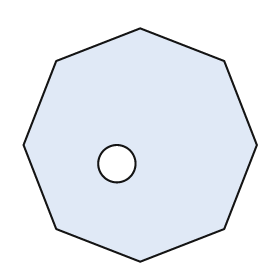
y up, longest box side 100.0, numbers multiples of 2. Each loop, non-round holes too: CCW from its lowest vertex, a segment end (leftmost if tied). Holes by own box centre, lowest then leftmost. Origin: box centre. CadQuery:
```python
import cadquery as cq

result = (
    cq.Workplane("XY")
    .moveTo(0.0, -50.0)
    .lineTo(36.0, -36.0)
    .lineTo(50.0, 0.0)
    .lineTo(36.0, 36.0)
    .lineTo(0.0, 50.0)
    .lineTo(-36.0, 36.0)
    .lineTo(-50.0, 0.0)
    .lineTo(-36.0, -36.0)
    .close()
    .moveTo(-10.0, -8.0)
    .circle(8.0)
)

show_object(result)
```